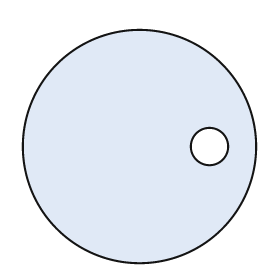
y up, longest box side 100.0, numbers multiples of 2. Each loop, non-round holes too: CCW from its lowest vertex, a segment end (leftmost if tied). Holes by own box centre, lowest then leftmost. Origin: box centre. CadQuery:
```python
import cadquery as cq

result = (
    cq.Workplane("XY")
    .moveTo(0.0, 0.0)
    .circle(50.0)
    .moveTo(30.0, 0.0)
    .circle(8.0)
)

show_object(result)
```